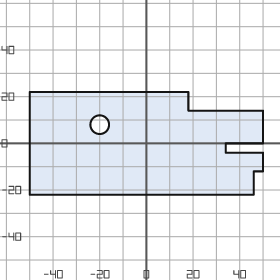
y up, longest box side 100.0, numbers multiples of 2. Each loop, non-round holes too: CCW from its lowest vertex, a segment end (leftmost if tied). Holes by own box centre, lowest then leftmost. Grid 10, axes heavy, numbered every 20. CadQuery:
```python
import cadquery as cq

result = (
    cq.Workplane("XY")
    .moveTo(-50.0, -22.0)
    .lineTo(46.0, -22.0)
    .lineTo(46.0, -12.0)
    .lineTo(50.0, -12.0)
    .lineTo(50.0, -4.0)
    .lineTo(34.0, -4.0)
    .lineTo(34.0, 0.0)
    .lineTo(50.0, 0.0)
    .lineTo(50.0, 14.0)
    .lineTo(18.0, 14.0)
    .lineTo(18.0, 22.0)
    .lineTo(-50.0, 22.0)
    .close()
    .moveTo(-20.0, 8.0)
    .circle(4.0)
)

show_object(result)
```